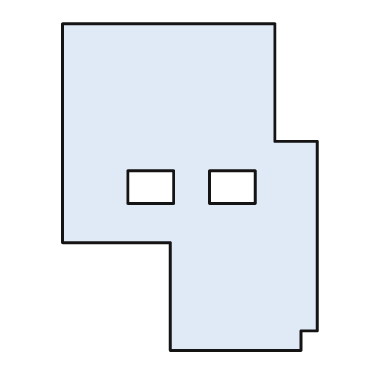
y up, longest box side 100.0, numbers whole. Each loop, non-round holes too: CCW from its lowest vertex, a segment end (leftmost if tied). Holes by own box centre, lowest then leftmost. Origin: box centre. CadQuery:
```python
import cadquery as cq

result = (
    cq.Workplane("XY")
    .moveTo(-6.0, -50.0)
    .lineTo(34.0, -50.0)
    .lineTo(34.0, -44.0)
    .lineTo(39.0, -44.0)
    .lineTo(39.0, 14.0)
    .lineTo(26.0, 14.0)
    .lineTo(26.0, 50.0)
    .lineTo(-39.0, 50.0)
    .lineTo(-39.0, -17.0)
    .lineTo(-6.0, -17.0)
    .close()
    .moveTo(-19.0, -5.0)
    .lineTo(-5.0, -5.0)
    .lineTo(-5.0, 5.0)
    .lineTo(-19.0, 5.0)
    .close()
    .moveTo(6.0, -5.0)
    .lineTo(20.0, -5.0)
    .lineTo(20.0, 5.0)
    .lineTo(6.0, 5.0)
    .close()
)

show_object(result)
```